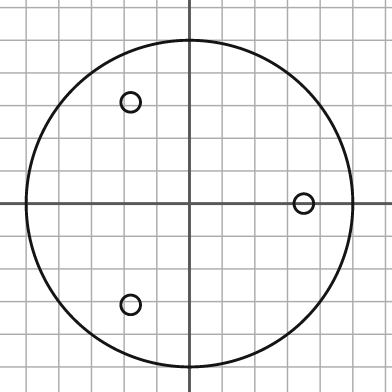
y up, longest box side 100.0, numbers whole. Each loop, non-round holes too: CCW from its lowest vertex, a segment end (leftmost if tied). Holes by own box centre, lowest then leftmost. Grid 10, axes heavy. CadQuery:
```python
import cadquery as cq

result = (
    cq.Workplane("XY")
    .moveTo(0.0, 0.0)
    .circle(50.0)
    .moveTo(-18.0, -31.0)
    .circle(3.0)
    .moveTo(35.0, 0.0)
    .circle(3.0)
    .moveTo(-18.0, 31.0)
    .circle(3.0)
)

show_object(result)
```